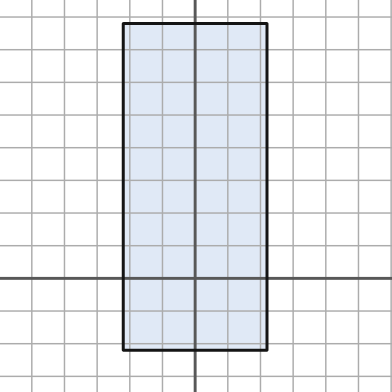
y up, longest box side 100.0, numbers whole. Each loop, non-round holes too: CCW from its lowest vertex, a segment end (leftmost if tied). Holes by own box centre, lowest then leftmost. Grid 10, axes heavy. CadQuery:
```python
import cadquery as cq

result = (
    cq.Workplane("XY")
    .moveTo(-22.0, -22.0)
    .lineTo(22.0, -22.0)
    .lineTo(22.0, 78.0)
    .lineTo(-22.0, 78.0)
    .close()
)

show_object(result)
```